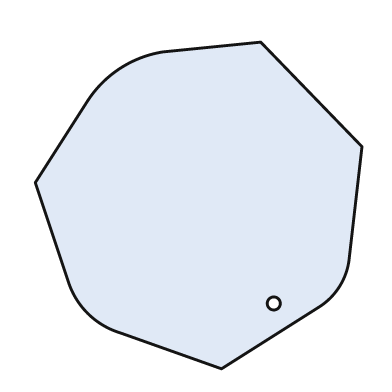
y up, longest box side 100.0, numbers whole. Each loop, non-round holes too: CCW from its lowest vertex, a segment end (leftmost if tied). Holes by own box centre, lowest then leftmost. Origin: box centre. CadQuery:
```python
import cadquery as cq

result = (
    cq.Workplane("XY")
    .moveTo(7.0, -50.0)
    .lineTo(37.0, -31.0)
    .threePointArc((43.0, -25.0), (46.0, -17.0))
    .lineTo(50.0, 18.0)
    .lineTo(19.0, 50.0)
    .lineTo(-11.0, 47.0)
    .threePointArc((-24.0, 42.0), (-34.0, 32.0))
    .lineTo(-50.0, 7.0)
    .lineTo(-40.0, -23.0)
    .threePointArc((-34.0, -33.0), (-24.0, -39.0))
    .close()
    .moveTo(23.0, -30.0)
    .circle(2.0)
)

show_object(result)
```